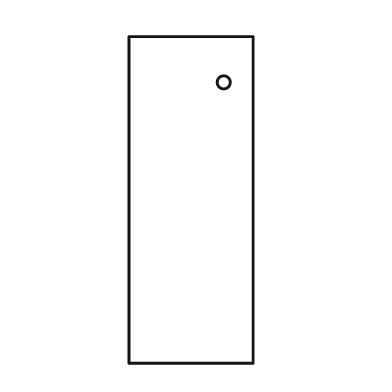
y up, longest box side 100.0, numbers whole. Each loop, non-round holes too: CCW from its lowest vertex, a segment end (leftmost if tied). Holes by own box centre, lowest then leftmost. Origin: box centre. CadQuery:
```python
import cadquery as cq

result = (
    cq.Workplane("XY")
    .moveTo(-19.0, -50.0)
    .lineTo(19.0, -50.0)
    .lineTo(19.0, 50.0)
    .lineTo(-19.0, 50.0)
    .close()
    .moveTo(10.0, 36.0)
    .circle(2.0)
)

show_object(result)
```